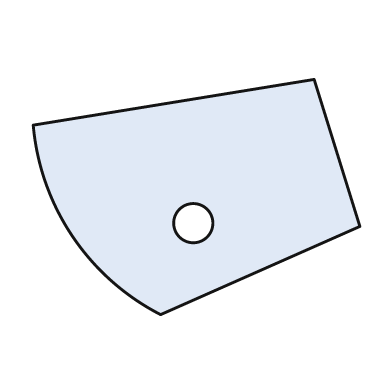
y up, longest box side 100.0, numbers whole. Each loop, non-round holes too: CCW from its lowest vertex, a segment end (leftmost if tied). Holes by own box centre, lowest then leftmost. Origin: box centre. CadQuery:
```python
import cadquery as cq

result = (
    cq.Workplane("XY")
    .moveTo(-11.0, -36.0)
    .lineTo(50.0, -9.0)
    .lineTo(36.0, 36.0)
    .lineTo(-50.0, 22.0)
    .threePointArc((-38.0, -12.0), (-11.0, -36.0))
    .close()
    .moveTo(-1.0, -8.0)
    .circle(6.0)
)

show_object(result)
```